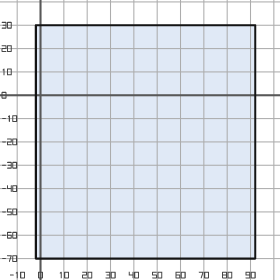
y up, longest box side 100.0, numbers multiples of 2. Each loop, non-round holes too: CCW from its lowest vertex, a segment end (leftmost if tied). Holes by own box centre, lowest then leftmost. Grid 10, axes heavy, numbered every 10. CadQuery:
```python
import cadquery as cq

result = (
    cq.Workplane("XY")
    .moveTo(-2.0, -70.0)
    .lineTo(92.0, -70.0)
    .lineTo(92.0, 30.0)
    .lineTo(-2.0, 30.0)
    .close()
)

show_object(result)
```